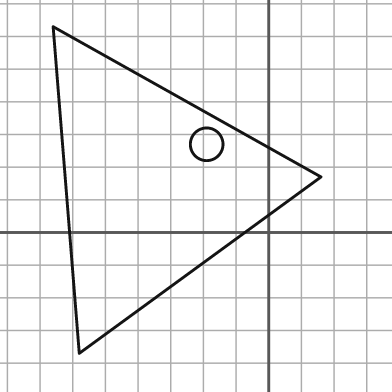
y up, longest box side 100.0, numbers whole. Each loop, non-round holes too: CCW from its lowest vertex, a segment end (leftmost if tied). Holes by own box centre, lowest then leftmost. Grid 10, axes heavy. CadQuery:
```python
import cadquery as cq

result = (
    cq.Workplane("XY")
    .moveTo(-58.0, -37.0)
    .lineTo(16.0, 17.0)
    .lineTo(-66.0, 63.0)
    .close()
    .moveTo(-19.0, 27.0)
    .circle(5.0)
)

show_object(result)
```